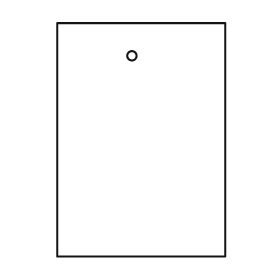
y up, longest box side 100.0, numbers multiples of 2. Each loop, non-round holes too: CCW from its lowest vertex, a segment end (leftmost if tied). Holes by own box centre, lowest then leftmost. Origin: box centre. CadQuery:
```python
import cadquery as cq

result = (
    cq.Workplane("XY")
    .moveTo(-36.0, -50.0)
    .lineTo(36.0, -50.0)
    .lineTo(36.0, 50.0)
    .lineTo(-36.0, 50.0)
    .close()
    .moveTo(-4.0, 36.0)
    .circle(2.0)
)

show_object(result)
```